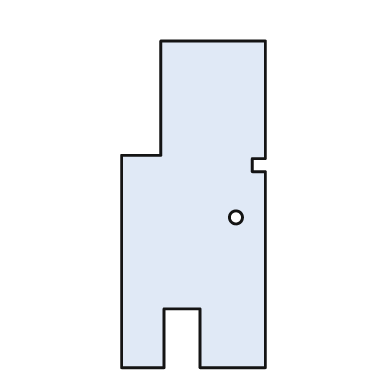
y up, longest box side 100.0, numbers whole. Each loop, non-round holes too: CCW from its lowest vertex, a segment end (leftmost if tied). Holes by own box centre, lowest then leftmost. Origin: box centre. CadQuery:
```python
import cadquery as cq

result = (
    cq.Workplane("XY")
    .moveTo(-22.0, -50.0)
    .lineTo(-9.0, -50.0)
    .lineTo(-9.0, -32.0)
    .lineTo(2.0, -32.0)
    .lineTo(2.0, -50.0)
    .lineTo(22.0, -50.0)
    .lineTo(22.0, 10.0)
    .lineTo(18.0, 10.0)
    .lineTo(18.0, 14.0)
    .lineTo(22.0, 14.0)
    .lineTo(22.0, 50.0)
    .lineTo(-10.0, 50.0)
    .lineTo(-10.0, 15.0)
    .lineTo(-22.0, 15.0)
    .close()
    .moveTo(13.0, -4.0)
    .circle(2.0)
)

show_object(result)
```